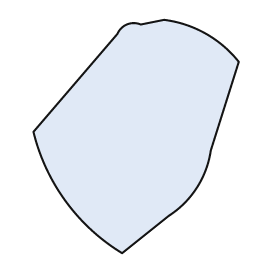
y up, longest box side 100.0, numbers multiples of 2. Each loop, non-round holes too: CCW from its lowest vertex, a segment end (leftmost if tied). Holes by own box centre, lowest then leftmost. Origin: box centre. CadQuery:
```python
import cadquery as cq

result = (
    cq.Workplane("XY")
    .moveTo(-6.0, -50.0)
    .lineTo(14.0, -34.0)
    .threePointArc((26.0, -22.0), (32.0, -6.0))
    .lineTo(44.0, 32.0)
    .threePointArc((30.0, 44.0), (12.0, 50.0))
    .lineTo(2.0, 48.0)
    .threePointArc((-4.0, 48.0), (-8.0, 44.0))
    .lineTo(-44.0, 2.0)
    .threePointArc((-30.0, -28.0), (-6.0, -50.0))
    .close()
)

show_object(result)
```